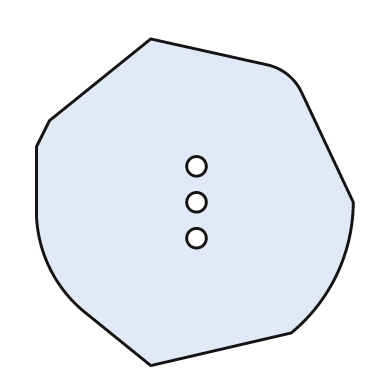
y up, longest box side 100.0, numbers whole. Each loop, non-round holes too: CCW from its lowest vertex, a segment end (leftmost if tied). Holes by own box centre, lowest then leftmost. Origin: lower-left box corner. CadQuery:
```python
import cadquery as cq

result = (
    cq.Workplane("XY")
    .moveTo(35.0, 0.0)
    .lineTo(78.0, 10.0)
    .threePointArc((92.0, 28.0), (97.0, 50.0))
    .lineTo(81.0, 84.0)
    .threePointArc((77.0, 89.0), (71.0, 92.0))
    .lineTo(35.0, 100.0)
    .lineTo(4.0, 75.0)
    .lineTo(0.0, 67.0)
    .lineTo(0.0, 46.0)
    .threePointArc((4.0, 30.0), (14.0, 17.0))
    .close()
    .moveTo(49.0, 39.0)
    .circle(3.0)
    .moveTo(49.0, 50.0)
    .circle(3.0)
    .moveTo(49.0, 61.0)
    .circle(3.0)
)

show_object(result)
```